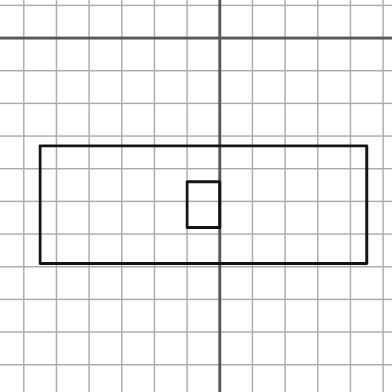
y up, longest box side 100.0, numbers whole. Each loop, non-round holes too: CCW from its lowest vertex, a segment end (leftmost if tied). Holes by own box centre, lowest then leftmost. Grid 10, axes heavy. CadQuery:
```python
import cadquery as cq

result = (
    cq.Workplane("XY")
    .moveTo(-55.0, -69.0)
    .lineTo(45.0, -69.0)
    .lineTo(45.0, -33.0)
    .lineTo(-55.0, -33.0)
    .close()
    .moveTo(-10.0, -58.0)
    .lineTo(0.0, -58.0)
    .lineTo(0.0, -44.0)
    .lineTo(-10.0, -44.0)
    .close()
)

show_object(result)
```